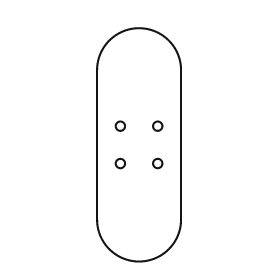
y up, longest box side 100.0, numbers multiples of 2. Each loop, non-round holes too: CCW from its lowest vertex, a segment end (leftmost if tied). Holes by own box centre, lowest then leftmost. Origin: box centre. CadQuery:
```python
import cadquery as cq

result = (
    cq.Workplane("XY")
    .moveTo(-18.0, -32.0)
    .threePointArc((0.0, -50.0), (18.0, -32.0))
    .lineTo(18.0, 32.0)
    .threePointArc((0.0, 50.0), (-18.0, 32.0))
    .close()
    .moveTo(-8.0, -8.0)
    .circle(2.0)
    .moveTo(8.0, -8.0)
    .circle(2.0)
    .moveTo(-8.0, 8.0)
    .circle(2.0)
    .moveTo(8.0, 8.0)
    .circle(2.0)
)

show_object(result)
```